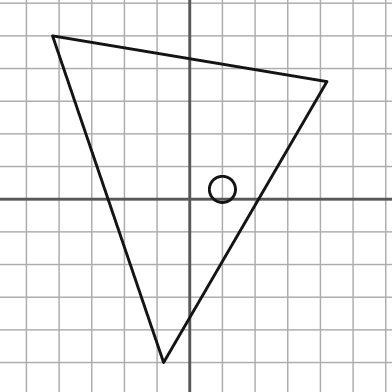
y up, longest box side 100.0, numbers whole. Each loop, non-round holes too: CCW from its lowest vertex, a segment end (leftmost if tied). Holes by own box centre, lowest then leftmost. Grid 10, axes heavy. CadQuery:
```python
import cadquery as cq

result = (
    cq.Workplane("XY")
    .moveTo(-8.0, -50.0)
    .lineTo(42.0, 36.0)
    .lineTo(-42.0, 50.0)
    .close()
    .moveTo(10.0, 3.0)
    .circle(4.0)
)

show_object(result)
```